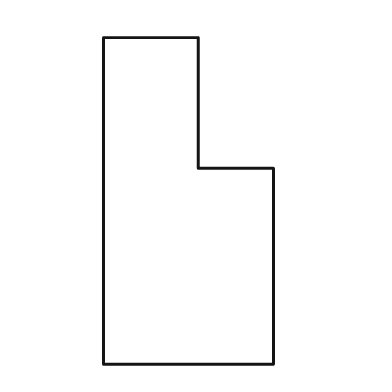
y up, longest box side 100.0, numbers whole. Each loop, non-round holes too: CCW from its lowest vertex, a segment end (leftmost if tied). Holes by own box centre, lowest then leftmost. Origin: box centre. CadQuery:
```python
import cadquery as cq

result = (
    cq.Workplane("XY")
    .moveTo(-26.0, -50.0)
    .lineTo(26.0, -50.0)
    .lineTo(26.0, 10.0)
    .lineTo(3.0, 10.0)
    .lineTo(3.0, 50.0)
    .lineTo(-26.0, 50.0)
    .close()
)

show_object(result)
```